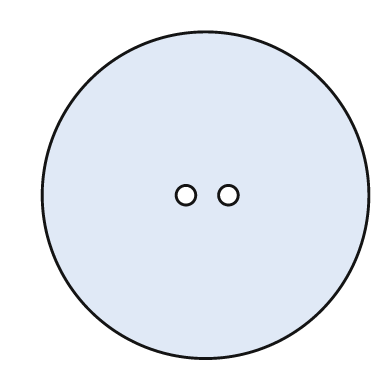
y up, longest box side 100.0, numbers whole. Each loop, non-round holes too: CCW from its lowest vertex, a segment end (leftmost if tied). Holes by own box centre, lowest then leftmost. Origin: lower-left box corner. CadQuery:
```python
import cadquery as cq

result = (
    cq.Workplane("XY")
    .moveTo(50.0, 50.0)
    .circle(50.0)
    .moveTo(44.0, 50.0)
    .circle(3.0)
    .moveTo(57.0, 50.0)
    .circle(3.0)
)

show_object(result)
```